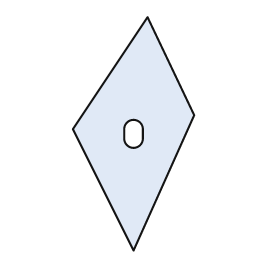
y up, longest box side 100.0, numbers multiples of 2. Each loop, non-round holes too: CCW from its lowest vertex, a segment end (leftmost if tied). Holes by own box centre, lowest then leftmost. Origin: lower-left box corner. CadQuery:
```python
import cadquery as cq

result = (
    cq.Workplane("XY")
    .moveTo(26.0, 0.0)
    .lineTo(52.0, 58.0)
    .lineTo(32.0, 100.0)
    .lineTo(0.0, 52.0)
    .close()
    .moveTo(22.0, 48.0)
    .threePointArc((26.0, 44.0), (30.0, 48.0))
    .lineTo(30.0, 52.0)
    .threePointArc((26.0, 56.0), (22.0, 52.0))
    .close()
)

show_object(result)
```